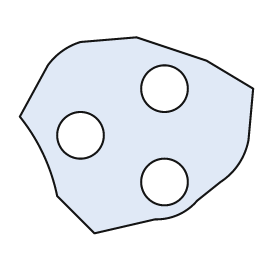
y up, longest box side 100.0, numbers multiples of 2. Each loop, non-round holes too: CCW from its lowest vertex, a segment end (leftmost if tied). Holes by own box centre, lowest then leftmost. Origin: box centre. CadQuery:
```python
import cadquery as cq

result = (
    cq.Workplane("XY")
    .moveTo(-18.0, -42.0)
    .lineTo(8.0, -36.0)
    .threePointArc((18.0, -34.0), (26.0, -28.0))
    .lineTo(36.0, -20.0)
    .threePointArc((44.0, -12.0), (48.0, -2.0))
    .lineTo(50.0, 20.0)
    .lineTo(30.0, 32.0)
    .lineTo(0.0, 42.0)
    .lineTo(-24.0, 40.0)
    .threePointArc((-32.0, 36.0), (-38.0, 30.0))
    .lineTo(-50.0, 8.0)
    .threePointArc((-40.0, -8.0), (-34.0, -26.0))
    .close()
    .moveTo(12.0, -20.0)
    .circle(10.0)
    .moveTo(-24.0, 0.0)
    .circle(10.0)
    .moveTo(12.0, 20.0)
    .circle(10.0)
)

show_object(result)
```